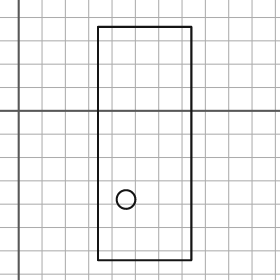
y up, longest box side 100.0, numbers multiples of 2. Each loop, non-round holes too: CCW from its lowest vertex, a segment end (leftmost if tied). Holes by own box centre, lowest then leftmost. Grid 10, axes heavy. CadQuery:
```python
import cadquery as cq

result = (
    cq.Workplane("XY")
    .moveTo(34.0, -64.0)
    .lineTo(74.0, -64.0)
    .lineTo(74.0, 36.0)
    .lineTo(34.0, 36.0)
    .close()
    .moveTo(46.0, -38.0)
    .circle(4.0)
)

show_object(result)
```